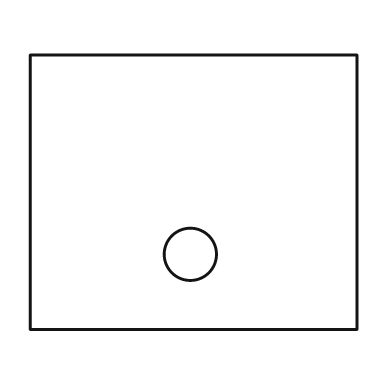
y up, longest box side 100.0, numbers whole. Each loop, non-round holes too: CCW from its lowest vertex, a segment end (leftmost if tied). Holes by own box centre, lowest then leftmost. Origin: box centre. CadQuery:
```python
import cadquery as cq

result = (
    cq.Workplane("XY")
    .moveTo(-50.0, -42.0)
    .lineTo(50.0, -42.0)
    .lineTo(50.0, 42.0)
    .lineTo(-50.0, 42.0)
    .close()
    .moveTo(-1.0, -19.0)
    .circle(8.0)
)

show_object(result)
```